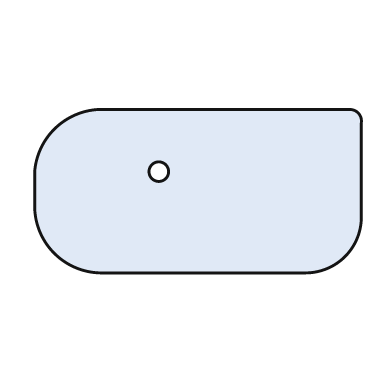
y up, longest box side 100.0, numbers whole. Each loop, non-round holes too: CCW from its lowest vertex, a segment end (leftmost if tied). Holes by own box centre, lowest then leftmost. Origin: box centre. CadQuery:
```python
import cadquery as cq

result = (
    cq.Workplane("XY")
    .moveTo(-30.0, -25.0)
    .lineTo(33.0, -25.0)
    .threePointArc((45.0, -20.0), (50.0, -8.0))
    .lineTo(50.0, 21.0)
    .threePointArc((49.0, 24.0), (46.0, 25.0))
    .lineTo(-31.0, 25.0)
    .threePointArc((-44.0, 19.0), (-50.0, 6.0))
    .lineTo(-50.0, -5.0)
    .threePointArc((-44.0, -19.0), (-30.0, -25.0))
    .close()
    .moveTo(-12.0, 6.0)
    .circle(3.0)
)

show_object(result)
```